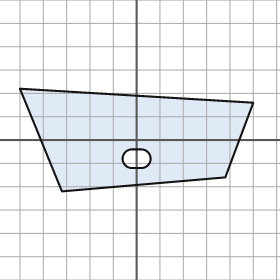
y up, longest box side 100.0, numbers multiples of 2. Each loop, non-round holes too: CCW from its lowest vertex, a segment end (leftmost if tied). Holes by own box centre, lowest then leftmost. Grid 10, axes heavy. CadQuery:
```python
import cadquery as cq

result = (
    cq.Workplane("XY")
    .moveTo(-32.0, -22.0)
    .lineTo(38.0, -16.0)
    .lineTo(50.0, 16.0)
    .lineTo(-50.0, 22.0)
    .close()
    .moveTo(-2.0, -12.0)
    .lineTo(2.0, -12.0)
    .threePointArc((6.0, -8.0), (2.0, -4.0))
    .lineTo(-2.0, -4.0)
    .threePointArc((-6.0, -8.0), (-2.0, -12.0))
    .close()
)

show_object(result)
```